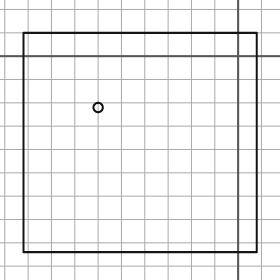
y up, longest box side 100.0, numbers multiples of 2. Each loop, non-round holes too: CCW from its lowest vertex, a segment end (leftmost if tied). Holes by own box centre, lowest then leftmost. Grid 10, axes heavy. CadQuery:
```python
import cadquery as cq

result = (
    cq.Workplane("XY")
    .moveTo(-92.0, -84.0)
    .lineTo(8.0, -84.0)
    .lineTo(8.0, 10.0)
    .lineTo(-92.0, 10.0)
    .close()
    .moveTo(-60.0, -22.0)
    .circle(2.0)
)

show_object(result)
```